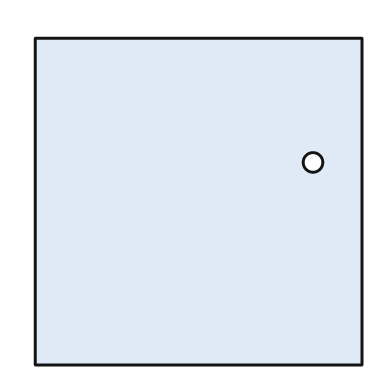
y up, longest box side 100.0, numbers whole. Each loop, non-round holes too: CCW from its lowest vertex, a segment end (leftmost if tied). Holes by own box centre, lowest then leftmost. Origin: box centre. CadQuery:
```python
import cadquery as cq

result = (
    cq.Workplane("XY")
    .moveTo(-50.0, -50.0)
    .lineTo(50.0, -50.0)
    .lineTo(50.0, 50.0)
    .lineTo(-50.0, 50.0)
    .close()
    .moveTo(35.0, 12.0)
    .circle(3.0)
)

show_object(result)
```